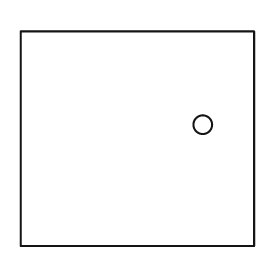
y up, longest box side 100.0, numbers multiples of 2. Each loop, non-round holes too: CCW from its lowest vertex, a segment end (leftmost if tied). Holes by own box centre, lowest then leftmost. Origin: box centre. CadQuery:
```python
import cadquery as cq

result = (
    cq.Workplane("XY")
    .moveTo(-50.0, -46.0)
    .lineTo(50.0, -46.0)
    .lineTo(50.0, 46.0)
    .lineTo(-50.0, 46.0)
    .close()
    .moveTo(28.0, 6.0)
    .circle(4.0)
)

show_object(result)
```